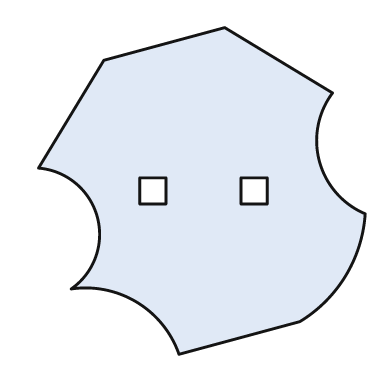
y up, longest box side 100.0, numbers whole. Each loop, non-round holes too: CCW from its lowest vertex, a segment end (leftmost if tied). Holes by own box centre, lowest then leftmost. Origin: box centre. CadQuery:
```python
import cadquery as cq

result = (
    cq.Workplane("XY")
    .moveTo(-7.0, -50.0)
    .lineTo(30.0, -40.0)
    .threePointArc((44.0, -26.0), (50.0, -7.0))
    .threePointArc((36.0, 9.0), (40.0, 30.0))
    .lineTo(7.0, 50.0)
    .lineTo(-30.0, 40.0)
    .lineTo(-50.0, 7.0)
    .threePointArc((-32.0, -8.0), (-40.0, -30.0))
    .threePointArc((-20.0, -34.0), (-7.0, -50.0))
    .close()
    .moveTo(-19.0, -4.0)
    .lineTo(-11.0, -4.0)
    .lineTo(-11.0, 4.0)
    .lineTo(-19.0, 4.0)
    .close()
    .moveTo(12.0, -4.0)
    .lineTo(20.0, -4.0)
    .lineTo(20.0, 4.0)
    .lineTo(12.0, 4.0)
    .close()
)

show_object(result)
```